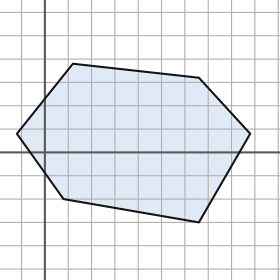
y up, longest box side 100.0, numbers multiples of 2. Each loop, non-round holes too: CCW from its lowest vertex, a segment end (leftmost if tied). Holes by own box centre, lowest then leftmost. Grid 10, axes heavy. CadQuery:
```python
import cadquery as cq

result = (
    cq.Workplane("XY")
    .moveTo(66.0, -30.0)
    .lineTo(88.0, 8.0)
    .lineTo(66.0, 32.0)
    .lineTo(12.0, 38.0)
    .lineTo(-12.0, 8.0)
    .lineTo(8.0, -20.0)
    .close()
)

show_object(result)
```